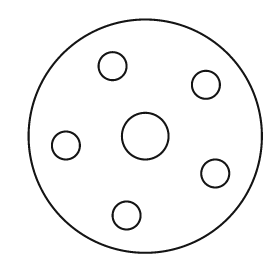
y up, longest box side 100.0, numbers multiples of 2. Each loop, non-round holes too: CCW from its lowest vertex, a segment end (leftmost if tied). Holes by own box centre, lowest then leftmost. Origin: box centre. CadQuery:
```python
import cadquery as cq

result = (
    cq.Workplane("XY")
    .moveTo(0.0, 0.0)
    .circle(50.0)
    .moveTo(-8.0, -34.0)
    .circle(6.0)
    .moveTo(30.0, -16.0)
    .circle(6.0)
    .moveTo(-34.0, -4.0)
    .circle(6.0)
    .moveTo(0.0, 0.0)
    .circle(10.0)
    .moveTo(26.0, 22.0)
    .circle(6.0)
    .moveTo(-14.0, 30.0)
    .circle(6.0)
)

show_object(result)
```